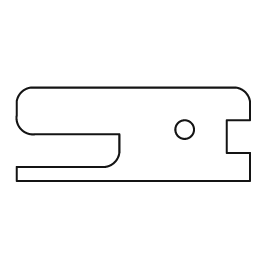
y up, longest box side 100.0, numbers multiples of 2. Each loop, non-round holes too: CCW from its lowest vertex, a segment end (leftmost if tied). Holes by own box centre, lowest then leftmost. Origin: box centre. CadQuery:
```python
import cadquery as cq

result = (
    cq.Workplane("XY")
    .moveTo(-50.0, -20.0)
    .lineTo(50.0, -20.0)
    .lineTo(50.0, -8.0)
    .lineTo(40.0, -8.0)
    .lineTo(40.0, 6.0)
    .lineTo(50.0, 6.0)
    .lineTo(50.0, 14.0)
    .threePointArc((48.0, 18.0), (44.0, 20.0))
    .lineTo(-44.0, 20.0)
    .threePointArc((-48.0, 18.0), (-50.0, 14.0))
    .lineTo(-50.0, 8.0)
    .threePointArc((-48.0, 2.0), (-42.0, 0.0))
    .lineTo(-6.0, 0.0)
    .lineTo(-6.0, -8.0)
    .threePointArc((-8.0, -12.0), (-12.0, -14.0))
    .lineTo(-50.0, -14.0)
    .close()
    .moveTo(22.0, 2.0)
    .circle(4.0)
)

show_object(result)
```